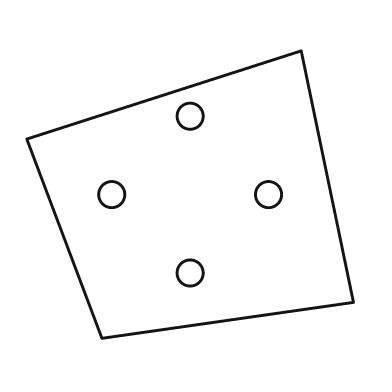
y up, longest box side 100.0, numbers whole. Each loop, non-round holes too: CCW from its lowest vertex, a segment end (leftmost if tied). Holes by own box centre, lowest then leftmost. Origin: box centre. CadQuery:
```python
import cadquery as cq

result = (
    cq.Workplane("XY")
    .moveTo(-27.0, -44.0)
    .lineTo(50.0, -33.0)
    .lineTo(34.0, 44.0)
    .lineTo(-50.0, 17.0)
    .close()
    .moveTo(0.0, -24.0)
    .circle(4.0)
    .moveTo(-24.0, 0.0)
    .circle(4.0)
    .moveTo(24.0, 0.0)
    .circle(4.0)
    .moveTo(0.0, 24.0)
    .circle(4.0)
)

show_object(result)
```